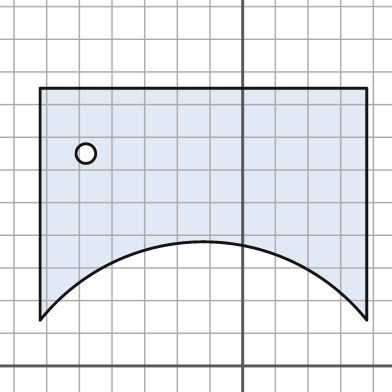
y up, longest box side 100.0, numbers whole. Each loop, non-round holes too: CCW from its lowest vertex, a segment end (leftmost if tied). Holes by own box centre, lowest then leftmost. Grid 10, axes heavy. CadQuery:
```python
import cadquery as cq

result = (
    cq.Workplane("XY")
    .moveTo(-62.0, 14.0)
    .threePointArc((-12.0, 38.0), (38.0, 14.0))
    .lineTo(38.0, 85.0)
    .lineTo(-62.0, 85.0)
    .close()
    .moveTo(-48.0, 65.0)
    .circle(3.0)
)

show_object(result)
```